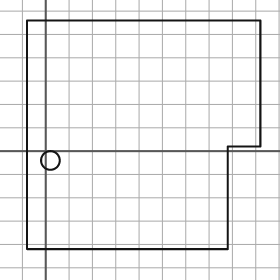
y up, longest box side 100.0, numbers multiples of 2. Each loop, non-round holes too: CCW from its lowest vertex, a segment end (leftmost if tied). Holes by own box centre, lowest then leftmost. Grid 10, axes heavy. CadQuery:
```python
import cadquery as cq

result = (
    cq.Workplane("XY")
    .moveTo(-8.0, -42.0)
    .lineTo(78.0, -42.0)
    .lineTo(78.0, 2.0)
    .lineTo(92.0, 2.0)
    .lineTo(92.0, 56.0)
    .lineTo(-8.0, 56.0)
    .close()
    .moveTo(2.0, -4.0)
    .circle(4.0)
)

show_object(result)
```